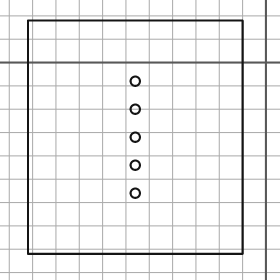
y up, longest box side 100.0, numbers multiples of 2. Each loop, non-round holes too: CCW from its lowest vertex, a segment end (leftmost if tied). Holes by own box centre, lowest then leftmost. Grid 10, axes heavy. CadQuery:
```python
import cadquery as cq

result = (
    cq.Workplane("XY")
    .moveTo(-102.0, -82.0)
    .lineTo(-10.0, -82.0)
    .lineTo(-10.0, 18.0)
    .lineTo(-102.0, 18.0)
    .close()
    .moveTo(-56.0, -56.0)
    .circle(2.0)
    .moveTo(-56.0, -44.0)
    .circle(2.0)
    .moveTo(-56.0, -32.0)
    .circle(2.0)
    .moveTo(-56.0, -20.0)
    .circle(2.0)
    .moveTo(-56.0, -8.0)
    .circle(2.0)
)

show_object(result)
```